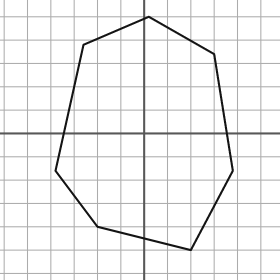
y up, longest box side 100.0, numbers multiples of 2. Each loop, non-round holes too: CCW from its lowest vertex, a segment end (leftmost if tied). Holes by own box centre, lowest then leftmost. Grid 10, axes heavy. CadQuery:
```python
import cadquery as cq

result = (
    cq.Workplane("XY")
    .moveTo(20.0, -50.0)
    .lineTo(38.0, -16.0)
    .lineTo(30.0, 34.0)
    .lineTo(2.0, 50.0)
    .lineTo(-26.0, 38.0)
    .lineTo(-38.0, -16.0)
    .lineTo(-20.0, -40.0)
    .close()
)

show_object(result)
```